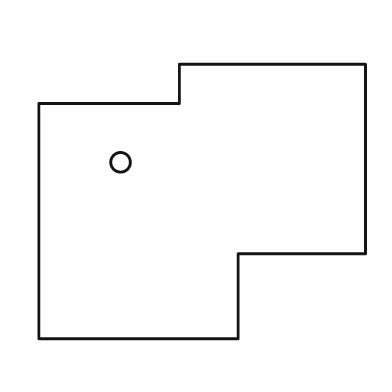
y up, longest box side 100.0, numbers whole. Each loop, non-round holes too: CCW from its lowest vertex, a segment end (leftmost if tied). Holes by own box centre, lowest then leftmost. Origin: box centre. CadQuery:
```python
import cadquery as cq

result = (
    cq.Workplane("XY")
    .moveTo(-50.0, -42.0)
    .lineTo(11.0, -42.0)
    .lineTo(11.0, -16.0)
    .lineTo(50.0, -16.0)
    .lineTo(50.0, 42.0)
    .lineTo(-7.0, 42.0)
    .lineTo(-7.0, 30.0)
    .lineTo(-50.0, 30.0)
    .close()
    .moveTo(-25.0, 12.0)
    .circle(3.0)
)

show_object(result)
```